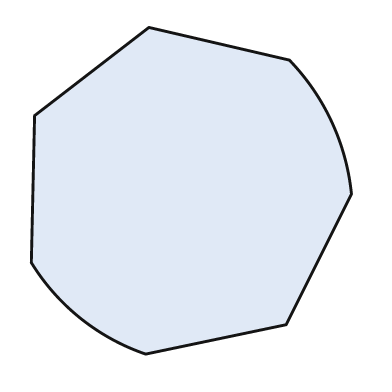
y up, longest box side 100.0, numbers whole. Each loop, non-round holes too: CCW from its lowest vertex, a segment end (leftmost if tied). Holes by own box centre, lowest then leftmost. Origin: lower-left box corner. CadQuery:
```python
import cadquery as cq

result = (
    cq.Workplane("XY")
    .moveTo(35.0, 0.0)
    .lineTo(78.0, 9.0)
    .lineTo(98.0, 49.0)
    .threePointArc((92.0, 71.0), (79.0, 90.0))
    .lineTo(36.0, 100.0)
    .lineTo(1.0, 73.0)
    .lineTo(0.0, 28.0)
    .threePointArc((15.0, 11.0), (35.0, 0.0))
    .close()
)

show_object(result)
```